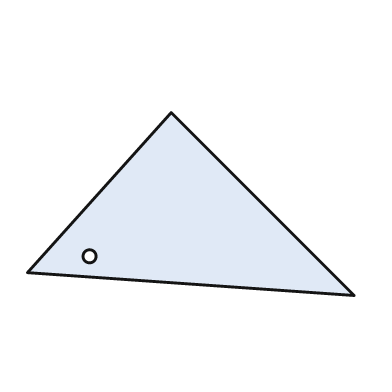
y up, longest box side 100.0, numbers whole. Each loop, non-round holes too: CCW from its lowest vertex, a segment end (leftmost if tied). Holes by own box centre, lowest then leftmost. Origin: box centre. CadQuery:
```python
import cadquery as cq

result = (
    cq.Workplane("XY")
    .moveTo(50.0, -28.0)
    .lineTo(-6.0, 28.0)
    .lineTo(-50.0, -21.0)
    .close()
    .moveTo(-31.0, -16.0)
    .circle(2.0)
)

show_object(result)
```